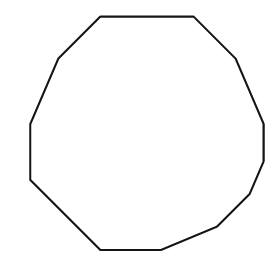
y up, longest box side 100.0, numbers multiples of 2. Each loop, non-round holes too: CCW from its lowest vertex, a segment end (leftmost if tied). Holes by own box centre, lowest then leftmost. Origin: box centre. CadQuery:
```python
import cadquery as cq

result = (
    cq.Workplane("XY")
    .moveTo(-20.0, -50.0)
    .lineTo(6.0, -50.0)
    .lineTo(30.0, -40.0)
    .lineTo(44.0, -26.0)
    .lineTo(50.0, -12.0)
    .lineTo(50.0, 4.0)
    .lineTo(38.0, 32.0)
    .lineTo(20.0, 50.0)
    .lineTo(-20.0, 50.0)
    .lineTo(-38.0, 32.0)
    .lineTo(-50.0, 4.0)
    .lineTo(-50.0, -20.0)
    .close()
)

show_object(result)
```